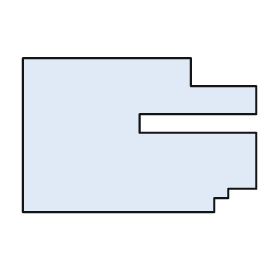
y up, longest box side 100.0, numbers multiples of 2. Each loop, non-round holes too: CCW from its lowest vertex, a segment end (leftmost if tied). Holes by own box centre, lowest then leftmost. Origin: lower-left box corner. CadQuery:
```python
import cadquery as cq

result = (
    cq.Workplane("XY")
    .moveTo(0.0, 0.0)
    .lineTo(82.0, 0.0)
    .lineTo(82.0, 6.0)
    .lineTo(88.0, 6.0)
    .lineTo(88.0, 10.0)
    .lineTo(100.0, 10.0)
    .lineTo(100.0, 34.0)
    .lineTo(50.0, 34.0)
    .lineTo(50.0, 42.0)
    .lineTo(100.0, 42.0)
    .lineTo(100.0, 54.0)
    .lineTo(72.0, 54.0)
    .lineTo(72.0, 66.0)
    .lineTo(0.0, 66.0)
    .close()
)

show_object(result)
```